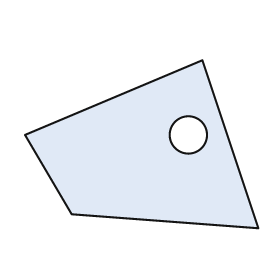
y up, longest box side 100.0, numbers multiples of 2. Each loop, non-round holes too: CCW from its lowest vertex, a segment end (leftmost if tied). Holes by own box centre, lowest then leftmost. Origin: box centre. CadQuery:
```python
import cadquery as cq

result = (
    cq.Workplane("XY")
    .moveTo(50.0, -36.0)
    .lineTo(26.0, 36.0)
    .lineTo(-50.0, 4.0)
    .lineTo(-30.0, -30.0)
    .close()
    .moveTo(20.0, 4.0)
    .circle(8.0)
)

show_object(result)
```